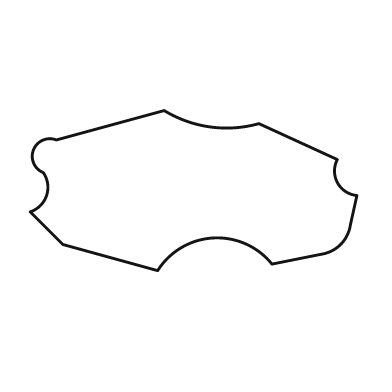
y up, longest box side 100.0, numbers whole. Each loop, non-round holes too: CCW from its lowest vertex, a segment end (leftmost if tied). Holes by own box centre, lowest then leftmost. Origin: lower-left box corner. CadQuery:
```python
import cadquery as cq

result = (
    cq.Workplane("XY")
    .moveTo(39.0, 0.0)
    .threePointArc((56.0, 10.0), (74.0, 2.0))
    .lineTo(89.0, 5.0)
    .threePointArc((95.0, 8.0), (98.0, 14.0))
    .lineTo(100.0, 23.0)
    .threePointArc((94.0, 27.0), (94.0, 34.0))
    .lineTo(70.0, 45.0)
    .threePointArc((55.0, 44.0), (41.0, 49.0))
    .lineTo(8.0, 40.0)
    .threePointArc((1.0, 37.0), (4.0, 30.0))
    .threePointArc((5.0, 23.0), (0.0, 18.0))
    .lineTo(10.0, 8.0)
    .close()
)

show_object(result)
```